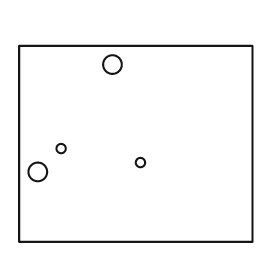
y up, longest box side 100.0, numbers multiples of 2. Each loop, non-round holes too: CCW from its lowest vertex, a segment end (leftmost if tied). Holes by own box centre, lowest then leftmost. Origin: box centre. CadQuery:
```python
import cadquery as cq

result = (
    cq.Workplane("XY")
    .moveTo(-50.0, -42.0)
    .lineTo(50.0, -42.0)
    .lineTo(50.0, 42.0)
    .lineTo(-50.0, 42.0)
    .close()
    .moveTo(-42.0, -12.0)
    .circle(4.0)
    .moveTo(2.0, -8.0)
    .circle(2.0)
    .moveTo(-32.0, -2.0)
    .circle(2.0)
    .moveTo(-10.0, 34.0)
    .circle(4.0)
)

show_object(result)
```